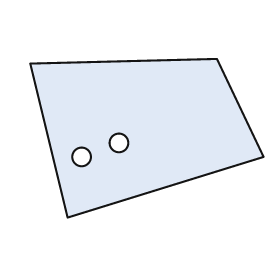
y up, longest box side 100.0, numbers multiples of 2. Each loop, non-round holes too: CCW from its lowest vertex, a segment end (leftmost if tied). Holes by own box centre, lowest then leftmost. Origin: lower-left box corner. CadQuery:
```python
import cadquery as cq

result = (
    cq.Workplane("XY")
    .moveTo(16.0, 0.0)
    .lineTo(100.0, 26.0)
    .lineTo(80.0, 68.0)
    .lineTo(0.0, 66.0)
    .close()
    .moveTo(22.0, 26.0)
    .circle(4.0)
    .moveTo(38.0, 32.0)
    .circle(4.0)
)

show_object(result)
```